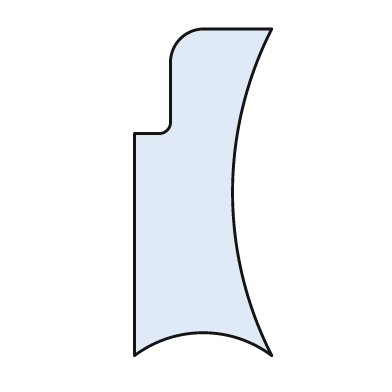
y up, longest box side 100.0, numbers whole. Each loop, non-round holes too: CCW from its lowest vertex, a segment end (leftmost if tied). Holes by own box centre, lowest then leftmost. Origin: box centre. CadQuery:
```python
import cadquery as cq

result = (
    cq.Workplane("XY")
    .moveTo(-21.0, -50.0)
    .threePointArc((0.0, -43.0), (21.0, -50.0))
    .threePointArc((9.0, 0.0), (21.0, 50.0))
    .lineTo(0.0, 50.0)
    .threePointArc((-7.0, 47.0), (-10.0, 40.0))
    .lineTo(-10.0, 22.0)
    .threePointArc((-11.0, 19.0), (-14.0, 18.0))
    .lineTo(-21.0, 18.0)
    .close()
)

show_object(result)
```